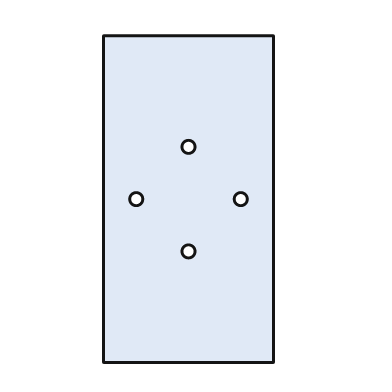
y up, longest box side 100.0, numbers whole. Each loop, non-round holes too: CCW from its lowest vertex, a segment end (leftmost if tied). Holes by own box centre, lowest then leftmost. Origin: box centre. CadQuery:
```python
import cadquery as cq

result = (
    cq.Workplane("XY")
    .moveTo(-26.0, -50.0)
    .lineTo(26.0, -50.0)
    .lineTo(26.0, 50.0)
    .lineTo(-26.0, 50.0)
    .close()
    .moveTo(0.0, -16.0)
    .circle(2.0)
    .moveTo(-16.0, 0.0)
    .circle(2.0)
    .moveTo(16.0, 0.0)
    .circle(2.0)
    .moveTo(0.0, 16.0)
    .circle(2.0)
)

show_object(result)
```